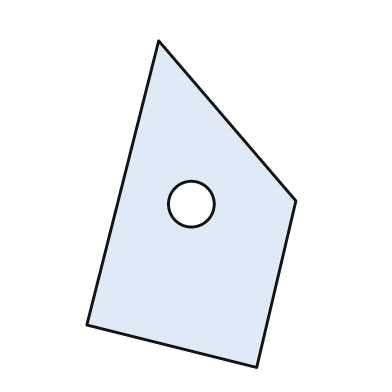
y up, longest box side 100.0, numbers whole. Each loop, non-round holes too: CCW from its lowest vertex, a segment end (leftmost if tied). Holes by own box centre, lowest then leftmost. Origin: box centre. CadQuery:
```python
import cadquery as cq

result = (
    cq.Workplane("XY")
    .moveTo(20.0, -50.0)
    .lineTo(32.0, 1.0)
    .lineTo(-10.0, 50.0)
    .lineTo(-32.0, -37.0)
    .close()
    .moveTo(0.0, 0.0)
    .circle(7.0)
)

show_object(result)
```